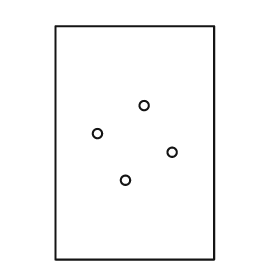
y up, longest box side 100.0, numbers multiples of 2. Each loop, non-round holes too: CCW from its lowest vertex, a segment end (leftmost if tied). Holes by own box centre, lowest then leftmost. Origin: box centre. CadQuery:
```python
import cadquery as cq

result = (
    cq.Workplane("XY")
    .moveTo(-34.0, -50.0)
    .lineTo(34.0, -50.0)
    .lineTo(34.0, 50.0)
    .lineTo(-34.0, 50.0)
    .close()
    .moveTo(-4.0, -16.0)
    .circle(2.0)
    .moveTo(16.0, -4.0)
    .circle(2.0)
    .moveTo(-16.0, 4.0)
    .circle(2.0)
    .moveTo(4.0, 16.0)
    .circle(2.0)
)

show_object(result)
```